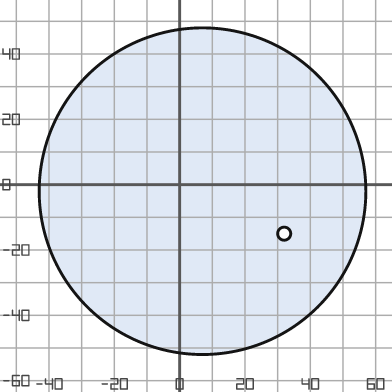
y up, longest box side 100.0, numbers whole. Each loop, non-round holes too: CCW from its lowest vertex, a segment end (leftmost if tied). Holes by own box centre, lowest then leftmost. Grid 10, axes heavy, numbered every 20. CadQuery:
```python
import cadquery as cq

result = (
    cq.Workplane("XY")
    .moveTo(7.0, -2.0)
    .circle(50.0)
    .moveTo(32.0, -15.0)
    .circle(2.0)
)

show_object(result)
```